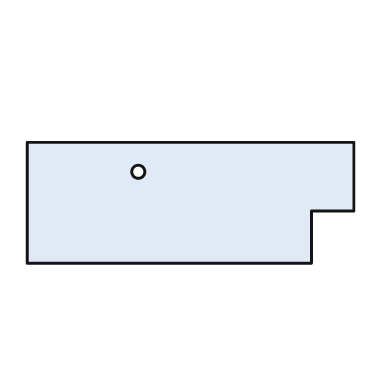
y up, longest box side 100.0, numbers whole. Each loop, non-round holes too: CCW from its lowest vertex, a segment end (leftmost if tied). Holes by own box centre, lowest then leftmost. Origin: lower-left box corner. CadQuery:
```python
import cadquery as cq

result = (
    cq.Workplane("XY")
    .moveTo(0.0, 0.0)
    .lineTo(87.0, 0.0)
    .lineTo(87.0, 16.0)
    .lineTo(100.0, 16.0)
    .lineTo(100.0, 37.0)
    .lineTo(0.0, 37.0)
    .close()
    .moveTo(34.0, 28.0)
    .circle(2.0)
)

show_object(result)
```